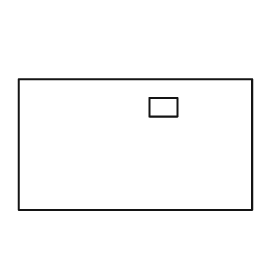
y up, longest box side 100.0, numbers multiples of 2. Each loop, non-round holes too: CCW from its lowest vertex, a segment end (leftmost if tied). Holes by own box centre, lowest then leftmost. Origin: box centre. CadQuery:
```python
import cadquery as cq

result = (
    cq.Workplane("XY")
    .moveTo(-50.0, -28.0)
    .lineTo(50.0, -28.0)
    .lineTo(50.0, 28.0)
    .lineTo(-50.0, 28.0)
    .close()
    .moveTo(6.0, 12.0)
    .lineTo(18.0, 12.0)
    .lineTo(18.0, 20.0)
    .lineTo(6.0, 20.0)
    .close()
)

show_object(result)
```